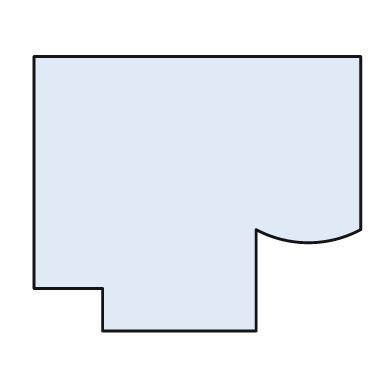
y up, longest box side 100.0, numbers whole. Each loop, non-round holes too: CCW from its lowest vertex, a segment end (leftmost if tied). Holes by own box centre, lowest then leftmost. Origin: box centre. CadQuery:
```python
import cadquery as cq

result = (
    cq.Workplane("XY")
    .moveTo(-29.0, -42.0)
    .lineTo(18.0, -42.0)
    .lineTo(18.0, -11.0)
    .threePointArc((34.0, -15.0), (50.0, -11.0))
    .lineTo(50.0, 42.0)
    .lineTo(-50.0, 42.0)
    .lineTo(-50.0, -29.0)
    .lineTo(-29.0, -29.0)
    .close()
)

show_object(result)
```